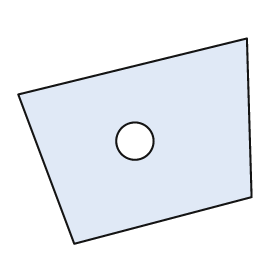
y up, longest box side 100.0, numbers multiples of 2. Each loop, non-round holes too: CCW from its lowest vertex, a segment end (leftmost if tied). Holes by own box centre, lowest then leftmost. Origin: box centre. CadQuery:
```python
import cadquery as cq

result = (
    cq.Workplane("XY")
    .moveTo(-26.0, -44.0)
    .lineTo(50.0, -24.0)
    .lineTo(48.0, 44.0)
    .lineTo(-50.0, 20.0)
    .close()
    .moveTo(0.0, 0.0)
    .circle(8.0)
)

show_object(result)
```